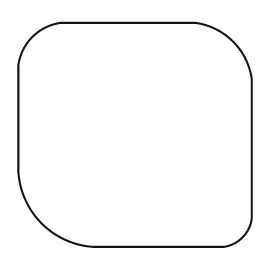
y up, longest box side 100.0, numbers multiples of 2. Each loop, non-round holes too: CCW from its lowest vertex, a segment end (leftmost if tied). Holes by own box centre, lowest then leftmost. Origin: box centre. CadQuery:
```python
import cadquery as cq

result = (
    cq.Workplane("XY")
    .moveTo(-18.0, -48.0)
    .lineTo(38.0, -48.0)
    .threePointArc((46.0, -44.0), (50.0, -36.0))
    .lineTo(50.0, 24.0)
    .threePointArc((42.0, 40.0), (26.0, 48.0))
    .lineTo(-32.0, 48.0)
    .threePointArc((-44.0, 42.0), (-50.0, 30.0))
    .lineTo(-50.0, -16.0)
    .threePointArc((-40.0, -38.0), (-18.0, -48.0))
    .close()
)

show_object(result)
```